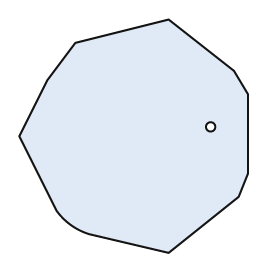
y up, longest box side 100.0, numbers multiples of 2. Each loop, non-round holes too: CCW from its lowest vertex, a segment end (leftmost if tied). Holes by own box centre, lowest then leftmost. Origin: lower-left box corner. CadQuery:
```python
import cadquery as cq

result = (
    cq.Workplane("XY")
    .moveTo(64.0, 0.0)
    .lineTo(94.0, 24.0)
    .lineTo(98.0, 34.0)
    .lineTo(98.0, 68.0)
    .lineTo(92.0, 78.0)
    .lineTo(64.0, 100.0)
    .lineTo(24.0, 90.0)
    .lineTo(12.0, 74.0)
    .lineTo(0.0, 50.0)
    .lineTo(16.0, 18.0)
    .threePointArc((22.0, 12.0), (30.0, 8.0))
    .close()
    .moveTo(82.0, 54.0)
    .circle(2.0)
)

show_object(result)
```